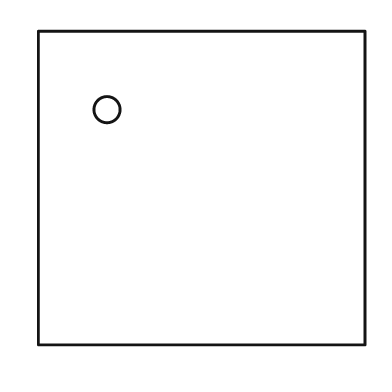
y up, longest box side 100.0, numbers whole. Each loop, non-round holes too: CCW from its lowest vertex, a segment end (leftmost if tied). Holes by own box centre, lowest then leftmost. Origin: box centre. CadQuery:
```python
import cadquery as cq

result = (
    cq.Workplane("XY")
    .moveTo(-50.0, -48.0)
    .lineTo(50.0, -48.0)
    .lineTo(50.0, 48.0)
    .lineTo(-50.0, 48.0)
    .close()
    .moveTo(-29.0, 24.0)
    .circle(4.0)
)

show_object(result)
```